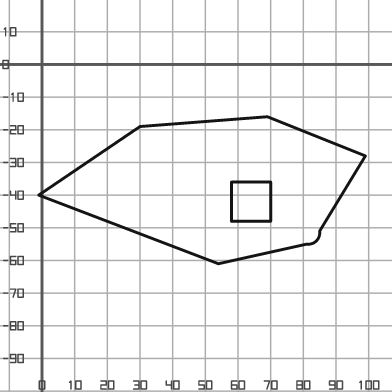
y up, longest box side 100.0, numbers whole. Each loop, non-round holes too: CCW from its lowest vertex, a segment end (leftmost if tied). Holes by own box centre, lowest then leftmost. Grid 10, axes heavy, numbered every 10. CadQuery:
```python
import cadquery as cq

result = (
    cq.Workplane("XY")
    .moveTo(54.0, -61.0)
    .lineTo(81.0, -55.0)
    .threePointArc((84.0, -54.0), (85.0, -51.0))
    .lineTo(99.0, -28.0)
    .lineTo(69.0, -16.0)
    .lineTo(30.0, -19.0)
    .lineTo(-1.0, -40.0)
    .close()
    .moveTo(58.0, -48.0)
    .lineTo(70.0, -48.0)
    .lineTo(70.0, -36.0)
    .lineTo(58.0, -36.0)
    .close()
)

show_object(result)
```